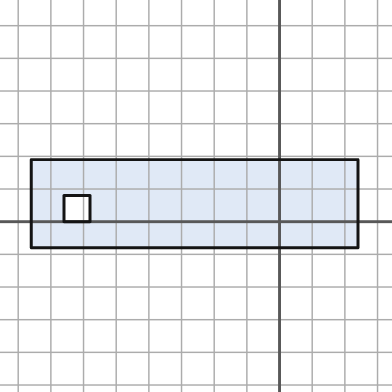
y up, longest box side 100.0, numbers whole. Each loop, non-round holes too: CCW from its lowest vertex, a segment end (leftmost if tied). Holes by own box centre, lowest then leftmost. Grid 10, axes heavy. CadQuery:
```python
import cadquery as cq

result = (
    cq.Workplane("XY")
    .moveTo(-76.0, -8.0)
    .lineTo(24.0, -8.0)
    .lineTo(24.0, 19.0)
    .lineTo(-76.0, 19.0)
    .close()
    .moveTo(-66.0, 0.0)
    .lineTo(-58.0, 0.0)
    .lineTo(-58.0, 8.0)
    .lineTo(-66.0, 8.0)
    .close()
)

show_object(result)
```